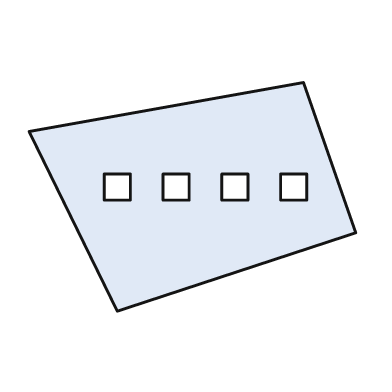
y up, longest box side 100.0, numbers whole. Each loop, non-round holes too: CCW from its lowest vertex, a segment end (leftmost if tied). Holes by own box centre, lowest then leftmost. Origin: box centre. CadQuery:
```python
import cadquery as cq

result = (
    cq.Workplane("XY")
    .moveTo(-23.0, -35.0)
    .lineTo(50.0, -11.0)
    .lineTo(34.0, 35.0)
    .lineTo(-50.0, 20.0)
    .close()
    .moveTo(-27.0, -1.0)
    .lineTo(-19.0, -1.0)
    .lineTo(-19.0, 7.0)
    .lineTo(-27.0, 7.0)
    .close()
    .moveTo(-9.0, -1.0)
    .lineTo(-1.0, -1.0)
    .lineTo(-1.0, 7.0)
    .lineTo(-9.0, 7.0)
    .close()
    .moveTo(9.0, -1.0)
    .lineTo(17.0, -1.0)
    .lineTo(17.0, 7.0)
    .lineTo(9.0, 7.0)
    .close()
    .moveTo(27.0, -1.0)
    .lineTo(35.0, -1.0)
    .lineTo(35.0, 7.0)
    .lineTo(27.0, 7.0)
    .close()
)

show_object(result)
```